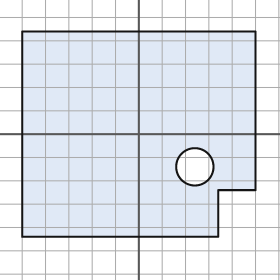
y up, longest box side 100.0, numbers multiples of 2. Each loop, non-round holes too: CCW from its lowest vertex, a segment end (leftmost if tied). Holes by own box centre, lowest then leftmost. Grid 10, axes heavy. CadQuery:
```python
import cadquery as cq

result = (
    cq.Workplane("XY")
    .moveTo(-50.0, -44.0)
    .lineTo(34.0, -44.0)
    .lineTo(34.0, -24.0)
    .lineTo(50.0, -24.0)
    .lineTo(50.0, 44.0)
    .lineTo(-50.0, 44.0)
    .close()
    .moveTo(24.0, -14.0)
    .circle(8.0)
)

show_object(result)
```